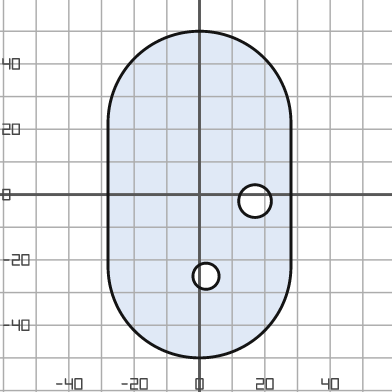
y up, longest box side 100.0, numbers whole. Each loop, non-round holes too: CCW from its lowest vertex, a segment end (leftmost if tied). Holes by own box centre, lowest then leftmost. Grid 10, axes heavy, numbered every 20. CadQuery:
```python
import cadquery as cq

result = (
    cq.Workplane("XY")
    .moveTo(-28.0, -22.0)
    .threePointArc((0.0, -50.0), (28.0, -22.0))
    .lineTo(28.0, 22.0)
    .threePointArc((0.0, 50.0), (-28.0, 22.0))
    .close()
    .moveTo(2.0, -25.0)
    .circle(4.0)
    .moveTo(17.0, -2.0)
    .circle(5.0)
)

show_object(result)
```